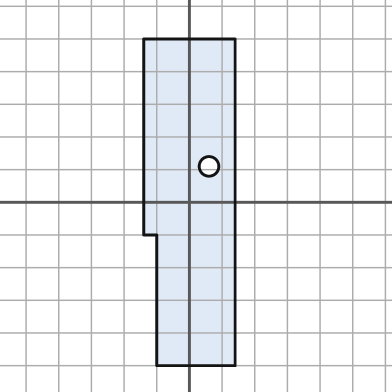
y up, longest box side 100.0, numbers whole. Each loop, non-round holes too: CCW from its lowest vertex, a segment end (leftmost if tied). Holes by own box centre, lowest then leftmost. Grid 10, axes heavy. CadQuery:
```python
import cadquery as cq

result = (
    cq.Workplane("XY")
    .moveTo(-10.0, -50.0)
    .lineTo(14.0, -50.0)
    .lineTo(14.0, 50.0)
    .lineTo(-14.0, 50.0)
    .lineTo(-14.0, -10.0)
    .lineTo(-10.0, -10.0)
    .close()
    .moveTo(6.0, 11.0)
    .circle(3.0)
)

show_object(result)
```